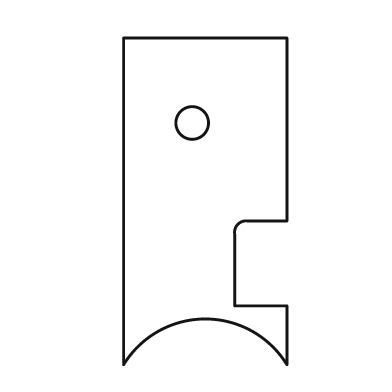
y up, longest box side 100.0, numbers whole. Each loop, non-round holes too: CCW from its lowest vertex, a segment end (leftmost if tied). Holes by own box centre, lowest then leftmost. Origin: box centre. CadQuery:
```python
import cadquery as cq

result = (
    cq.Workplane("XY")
    .moveTo(-25.0, -50.0)
    .threePointArc((0.0, -36.0), (25.0, -50.0))
    .lineTo(25.0, -32.0)
    .lineTo(9.0, -32.0)
    .lineTo(9.0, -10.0)
    .threePointArc((10.0, -7.0), (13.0, -6.0))
    .lineTo(25.0, -6.0)
    .lineTo(25.0, 50.0)
    .lineTo(-25.0, 50.0)
    .close()
    .moveTo(-4.0, 24.0)
    .circle(5.0)
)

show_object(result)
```